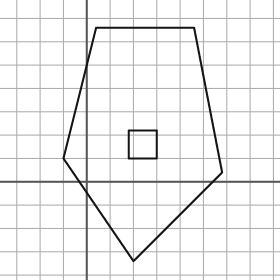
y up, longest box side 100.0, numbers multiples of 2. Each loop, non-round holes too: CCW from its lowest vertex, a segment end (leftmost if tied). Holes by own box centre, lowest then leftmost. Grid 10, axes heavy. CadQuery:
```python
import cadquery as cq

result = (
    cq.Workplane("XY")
    .moveTo(20.0, -34.0)
    .lineTo(58.0, 4.0)
    .lineTo(46.0, 66.0)
    .lineTo(4.0, 66.0)
    .lineTo(-10.0, 10.0)
    .close()
    .moveTo(18.0, 10.0)
    .lineTo(30.0, 10.0)
    .lineTo(30.0, 22.0)
    .lineTo(18.0, 22.0)
    .close()
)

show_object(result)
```